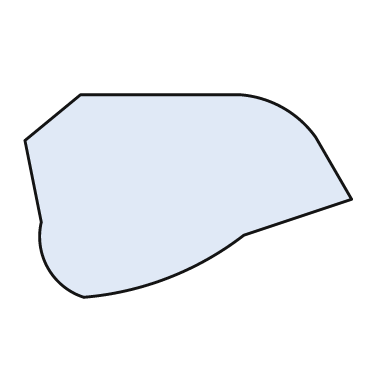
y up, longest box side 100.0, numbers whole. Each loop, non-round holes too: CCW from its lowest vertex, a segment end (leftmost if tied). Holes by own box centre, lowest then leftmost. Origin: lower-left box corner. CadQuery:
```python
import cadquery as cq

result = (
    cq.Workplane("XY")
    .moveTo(18.0, 0.0)
    .threePointArc((44.0, 6.0), (67.0, 19.0))
    .lineTo(100.0, 30.0)
    .lineTo(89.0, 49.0)
    .threePointArc((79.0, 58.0), (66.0, 62.0))
    .lineTo(17.0, 62.0)
    .lineTo(0.0, 48.0)
    .lineTo(5.0, 23.0)
    .threePointArc((7.0, 9.0), (18.0, 0.0))
    .close()
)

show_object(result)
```